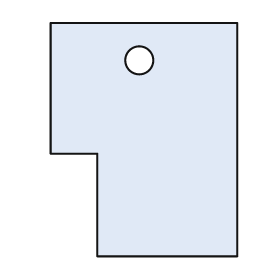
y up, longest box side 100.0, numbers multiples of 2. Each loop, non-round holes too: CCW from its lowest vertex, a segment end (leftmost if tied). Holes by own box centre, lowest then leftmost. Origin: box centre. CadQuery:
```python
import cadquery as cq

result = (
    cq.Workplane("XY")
    .moveTo(-20.0, -50.0)
    .lineTo(40.0, -50.0)
    .lineTo(40.0, 50.0)
    .lineTo(-40.0, 50.0)
    .lineTo(-40.0, -6.0)
    .lineTo(-20.0, -6.0)
    .close()
    .moveTo(-2.0, 34.0)
    .circle(6.0)
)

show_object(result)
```